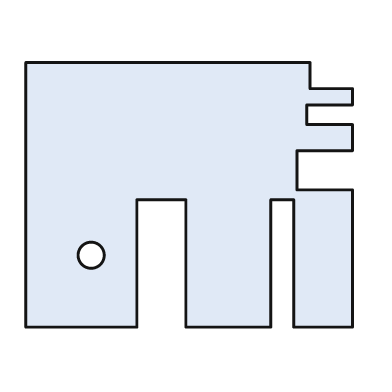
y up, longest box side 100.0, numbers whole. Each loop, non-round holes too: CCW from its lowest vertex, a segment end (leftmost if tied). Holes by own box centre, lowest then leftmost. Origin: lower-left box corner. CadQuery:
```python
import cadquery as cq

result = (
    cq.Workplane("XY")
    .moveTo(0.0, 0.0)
    .lineTo(34.0, 0.0)
    .lineTo(34.0, 39.0)
    .lineTo(49.0, 39.0)
    .lineTo(49.0, 0.0)
    .lineTo(75.0, 0.0)
    .lineTo(75.0, 39.0)
    .lineTo(82.0, 39.0)
    .lineTo(82.0, 0.0)
    .lineTo(100.0, 0.0)
    .lineTo(100.0, 42.0)
    .lineTo(83.0, 42.0)
    .lineTo(83.0, 54.0)
    .lineTo(100.0, 54.0)
    .lineTo(100.0, 62.0)
    .lineTo(86.0, 62.0)
    .lineTo(86.0, 68.0)
    .lineTo(100.0, 68.0)
    .lineTo(100.0, 73.0)
    .lineTo(87.0, 73.0)
    .lineTo(87.0, 81.0)
    .lineTo(0.0, 81.0)
    .close()
    .moveTo(20.0, 22.0)
    .circle(4.0)
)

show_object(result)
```